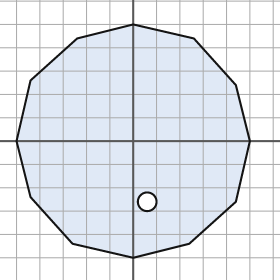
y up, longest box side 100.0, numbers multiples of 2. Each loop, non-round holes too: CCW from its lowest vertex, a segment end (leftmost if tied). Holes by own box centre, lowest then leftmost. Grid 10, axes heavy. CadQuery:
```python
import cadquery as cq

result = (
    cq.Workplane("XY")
    .moveTo(0.0, -50.0)
    .lineTo(24.0, -44.0)
    .lineTo(44.0, -26.0)
    .lineTo(50.0, 0.0)
    .lineTo(44.0, 24.0)
    .lineTo(26.0, 44.0)
    .lineTo(0.0, 50.0)
    .lineTo(-24.0, 44.0)
    .lineTo(-44.0, 26.0)
    .lineTo(-50.0, 0.0)
    .lineTo(-44.0, -24.0)
    .lineTo(-26.0, -44.0)
    .close()
    .moveTo(6.0, -26.0)
    .circle(4.0)
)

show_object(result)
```